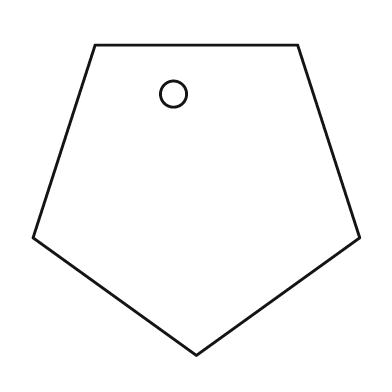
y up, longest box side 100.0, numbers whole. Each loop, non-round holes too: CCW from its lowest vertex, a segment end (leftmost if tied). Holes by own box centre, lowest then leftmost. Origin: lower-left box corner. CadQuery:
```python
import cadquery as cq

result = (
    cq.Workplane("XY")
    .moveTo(50.0, 0.0)
    .lineTo(100.0, 36.0)
    .lineTo(81.0, 95.0)
    .lineTo(19.0, 95.0)
    .lineTo(0.0, 36.0)
    .close()
    .moveTo(43.0, 80.0)
    .circle(4.0)
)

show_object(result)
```